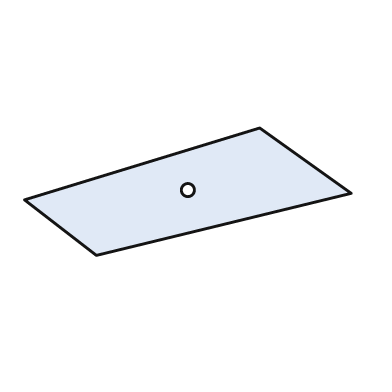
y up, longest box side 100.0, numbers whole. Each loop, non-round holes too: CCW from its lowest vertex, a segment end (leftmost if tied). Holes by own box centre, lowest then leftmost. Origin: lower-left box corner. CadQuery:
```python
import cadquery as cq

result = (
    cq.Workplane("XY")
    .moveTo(22.0, 0.0)
    .lineTo(100.0, 19.0)
    .lineTo(72.0, 39.0)
    .lineTo(0.0, 17.0)
    .close()
    .moveTo(50.0, 20.0)
    .circle(2.0)
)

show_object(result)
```